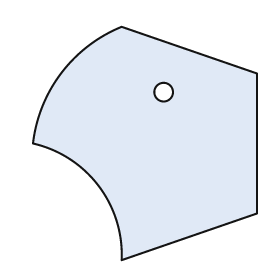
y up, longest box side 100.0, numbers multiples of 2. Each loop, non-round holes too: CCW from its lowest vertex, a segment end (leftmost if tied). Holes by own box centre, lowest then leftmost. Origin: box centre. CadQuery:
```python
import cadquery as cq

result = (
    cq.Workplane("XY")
    .moveTo(-10.0, -50.0)
    .lineTo(48.0, -30.0)
    .lineTo(48.0, 30.0)
    .lineTo(-10.0, 50.0)
    .threePointArc((-36.0, 30.0), (-48.0, 0.0))
    .threePointArc((-20.0, -18.0), (-10.0, -50.0))
    .close()
    .moveTo(8.0, 22.0)
    .circle(4.0)
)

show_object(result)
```